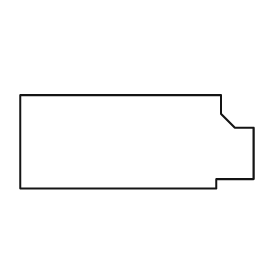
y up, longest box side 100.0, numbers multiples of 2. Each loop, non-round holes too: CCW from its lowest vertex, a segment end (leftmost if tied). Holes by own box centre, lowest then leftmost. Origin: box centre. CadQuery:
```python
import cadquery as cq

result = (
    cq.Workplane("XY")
    .moveTo(-50.0, -20.0)
    .lineTo(34.0, -20.0)
    .lineTo(34.0, -16.0)
    .lineTo(50.0, -16.0)
    .lineTo(50.0, 6.0)
    .lineTo(42.0, 6.0)
    .lineTo(36.0, 12.0)
    .lineTo(36.0, 20.0)
    .lineTo(-50.0, 20.0)
    .close()
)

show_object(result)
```